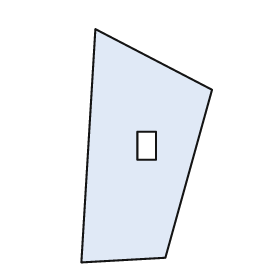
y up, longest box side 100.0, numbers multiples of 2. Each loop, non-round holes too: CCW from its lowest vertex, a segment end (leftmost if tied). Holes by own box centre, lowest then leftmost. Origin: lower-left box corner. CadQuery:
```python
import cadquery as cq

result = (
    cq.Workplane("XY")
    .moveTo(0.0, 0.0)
    .lineTo(36.0, 2.0)
    .lineTo(56.0, 74.0)
    .lineTo(6.0, 100.0)
    .close()
    .moveTo(24.0, 44.0)
    .lineTo(32.0, 44.0)
    .lineTo(32.0, 56.0)
    .lineTo(24.0, 56.0)
    .close()
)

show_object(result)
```